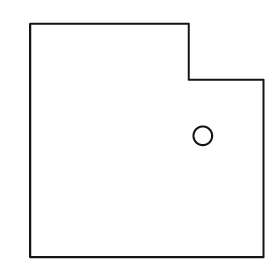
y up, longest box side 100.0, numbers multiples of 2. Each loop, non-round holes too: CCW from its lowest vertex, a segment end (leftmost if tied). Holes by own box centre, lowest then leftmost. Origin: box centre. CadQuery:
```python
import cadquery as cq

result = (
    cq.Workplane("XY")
    .moveTo(-50.0, -50.0)
    .lineTo(50.0, -50.0)
    .lineTo(50.0, 26.0)
    .lineTo(18.0, 26.0)
    .lineTo(18.0, 50.0)
    .lineTo(-50.0, 50.0)
    .close()
    .moveTo(24.0, 2.0)
    .circle(4.0)
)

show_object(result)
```